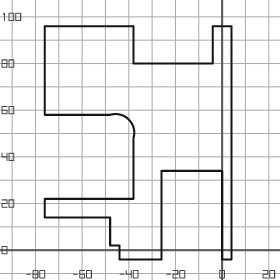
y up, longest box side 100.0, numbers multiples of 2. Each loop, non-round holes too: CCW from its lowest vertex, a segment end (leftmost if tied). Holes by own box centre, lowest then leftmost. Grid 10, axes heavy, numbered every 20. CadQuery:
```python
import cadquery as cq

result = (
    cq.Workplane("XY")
    .moveTo(-44.0, -4.0)
    .lineTo(-26.0, -4.0)
    .lineTo(-26.0, 34.0)
    .lineTo(0.0, 34.0)
    .lineTo(0.0, -4.0)
    .lineTo(4.0, -4.0)
    .lineTo(4.0, 96.0)
    .lineTo(-4.0, 96.0)
    .lineTo(-4.0, 80.0)
    .lineTo(-38.0, 80.0)
    .lineTo(-38.0, 96.0)
    .lineTo(-76.0, 96.0)
    .lineTo(-76.0, 58.0)
    .lineTo(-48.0, 58.0)
    .threePointArc((-40.0, 56.0), (-38.0, 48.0))
    .lineTo(-38.0, 22.0)
    .lineTo(-76.0, 22.0)
    .lineTo(-76.0, 14.0)
    .lineTo(-48.0, 14.0)
    .lineTo(-48.0, 2.0)
    .lineTo(-44.0, 2.0)
    .close()
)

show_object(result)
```